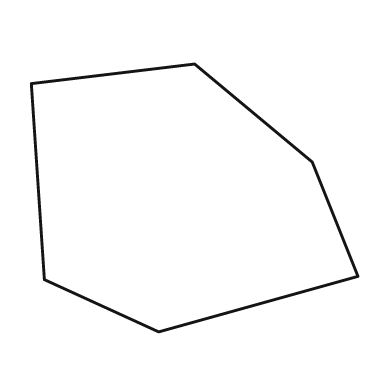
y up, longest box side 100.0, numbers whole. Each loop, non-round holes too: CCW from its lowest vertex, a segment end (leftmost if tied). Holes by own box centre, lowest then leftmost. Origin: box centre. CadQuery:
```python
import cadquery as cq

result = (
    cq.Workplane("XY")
    .moveTo(-11.0, -41.0)
    .lineTo(50.0, -24.0)
    .lineTo(36.0, 11.0)
    .lineTo(0.0, 41.0)
    .lineTo(-50.0, 35.0)
    .lineTo(-46.0, -25.0)
    .close()
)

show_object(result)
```